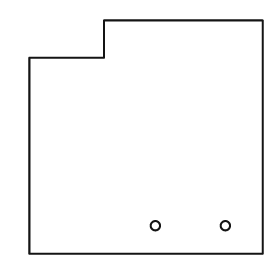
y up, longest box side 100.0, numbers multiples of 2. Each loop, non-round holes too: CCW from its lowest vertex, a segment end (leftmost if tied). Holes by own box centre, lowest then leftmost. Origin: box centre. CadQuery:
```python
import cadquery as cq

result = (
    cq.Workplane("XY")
    .moveTo(-50.0, -50.0)
    .lineTo(50.0, -50.0)
    .lineTo(50.0, 50.0)
    .lineTo(-18.0, 50.0)
    .lineTo(-18.0, 34.0)
    .lineTo(-50.0, 34.0)
    .close()
    .moveTo(4.0, -38.0)
    .circle(2.0)
    .moveTo(34.0, -38.0)
    .circle(2.0)
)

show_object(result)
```